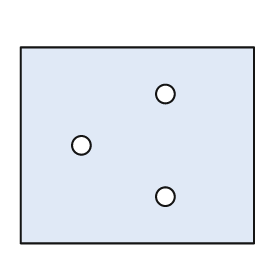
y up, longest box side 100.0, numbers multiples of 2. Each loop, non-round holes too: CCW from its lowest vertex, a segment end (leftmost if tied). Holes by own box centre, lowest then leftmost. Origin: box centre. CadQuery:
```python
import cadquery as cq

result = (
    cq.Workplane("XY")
    .moveTo(-50.0, -42.0)
    .lineTo(50.0, -42.0)
    .lineTo(50.0, 42.0)
    .lineTo(-50.0, 42.0)
    .close()
    .moveTo(12.0, -22.0)
    .circle(4.0)
    .moveTo(-24.0, 0.0)
    .circle(4.0)
    .moveTo(12.0, 22.0)
    .circle(4.0)
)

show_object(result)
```